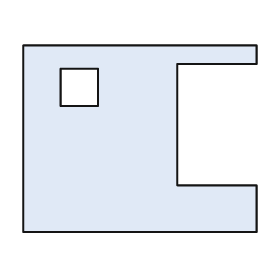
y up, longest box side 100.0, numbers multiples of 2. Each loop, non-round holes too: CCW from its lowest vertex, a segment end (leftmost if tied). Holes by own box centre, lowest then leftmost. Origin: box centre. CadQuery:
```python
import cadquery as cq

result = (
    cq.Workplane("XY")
    .moveTo(-50.0, -40.0)
    .lineTo(50.0, -40.0)
    .lineTo(50.0, -20.0)
    .lineTo(16.0, -20.0)
    .lineTo(16.0, 32.0)
    .lineTo(50.0, 32.0)
    .lineTo(50.0, 40.0)
    .lineTo(-50.0, 40.0)
    .close()
    .moveTo(-34.0, 14.0)
    .lineTo(-18.0, 14.0)
    .lineTo(-18.0, 30.0)
    .lineTo(-34.0, 30.0)
    .close()
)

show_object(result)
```